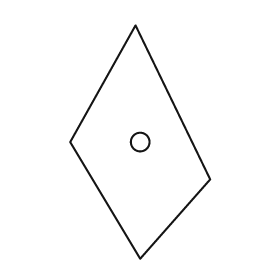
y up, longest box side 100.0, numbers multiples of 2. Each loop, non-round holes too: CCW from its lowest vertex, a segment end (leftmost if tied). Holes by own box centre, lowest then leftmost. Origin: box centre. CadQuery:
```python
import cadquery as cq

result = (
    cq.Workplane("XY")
    .moveTo(0.0, -50.0)
    .lineTo(30.0, -16.0)
    .lineTo(-2.0, 50.0)
    .lineTo(-30.0, 0.0)
    .close()
    .moveTo(0.0, 0.0)
    .circle(4.0)
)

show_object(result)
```